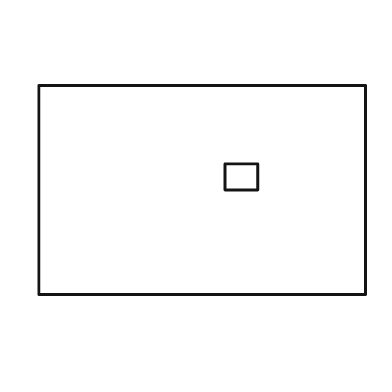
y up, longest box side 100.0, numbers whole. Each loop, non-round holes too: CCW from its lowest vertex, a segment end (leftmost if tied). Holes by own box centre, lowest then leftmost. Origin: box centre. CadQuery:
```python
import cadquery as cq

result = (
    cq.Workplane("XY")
    .moveTo(-50.0, -32.0)
    .lineTo(50.0, -32.0)
    .lineTo(50.0, 32.0)
    .lineTo(-50.0, 32.0)
    .close()
    .moveTo(7.0, 0.0)
    .lineTo(17.0, 0.0)
    .lineTo(17.0, 8.0)
    .lineTo(7.0, 8.0)
    .close()
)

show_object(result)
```